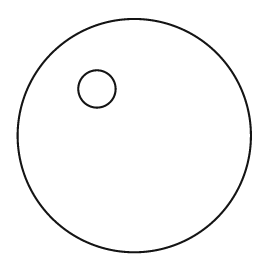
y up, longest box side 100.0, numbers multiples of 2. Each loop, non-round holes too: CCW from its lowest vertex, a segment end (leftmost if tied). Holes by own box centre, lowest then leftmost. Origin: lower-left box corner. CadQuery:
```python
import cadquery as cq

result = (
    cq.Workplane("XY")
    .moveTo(50.0, 50.0)
    .circle(50.0)
    .moveTo(34.0, 70.0)
    .circle(8.0)
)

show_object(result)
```